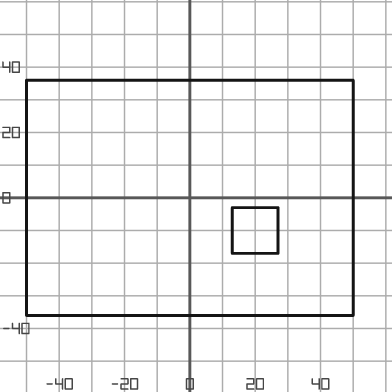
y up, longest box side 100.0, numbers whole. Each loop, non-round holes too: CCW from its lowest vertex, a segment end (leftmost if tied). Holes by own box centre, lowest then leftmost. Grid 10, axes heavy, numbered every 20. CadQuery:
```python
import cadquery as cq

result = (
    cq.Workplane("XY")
    .moveTo(-50.0, -36.0)
    .lineTo(50.0, -36.0)
    .lineTo(50.0, 36.0)
    .lineTo(-50.0, 36.0)
    .close()
    .moveTo(13.0, -17.0)
    .lineTo(27.0, -17.0)
    .lineTo(27.0, -3.0)
    .lineTo(13.0, -3.0)
    .close()
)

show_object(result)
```